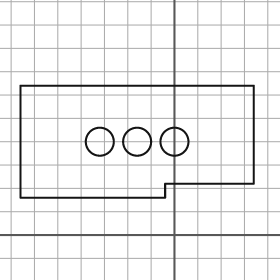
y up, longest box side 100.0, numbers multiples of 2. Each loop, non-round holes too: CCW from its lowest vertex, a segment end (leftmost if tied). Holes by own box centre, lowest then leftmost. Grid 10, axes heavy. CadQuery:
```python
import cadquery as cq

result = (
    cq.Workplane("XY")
    .moveTo(-66.0, 16.0)
    .lineTo(-4.0, 16.0)
    .lineTo(-4.0, 22.0)
    .lineTo(34.0, 22.0)
    .lineTo(34.0, 64.0)
    .lineTo(-66.0, 64.0)
    .close()
    .moveTo(-32.0, 40.0)
    .circle(6.0)
    .moveTo(-16.0, 40.0)
    .circle(6.0)
    .moveTo(0.0, 40.0)
    .circle(6.0)
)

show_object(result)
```